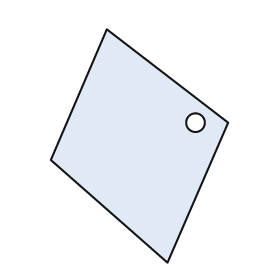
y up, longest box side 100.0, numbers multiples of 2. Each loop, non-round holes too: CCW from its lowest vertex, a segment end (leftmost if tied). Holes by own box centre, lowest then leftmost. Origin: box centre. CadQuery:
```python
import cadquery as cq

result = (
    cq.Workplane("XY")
    .moveTo(12.0, -50.0)
    .lineTo(38.0, 10.0)
    .lineTo(-14.0, 50.0)
    .lineTo(-38.0, -6.0)
    .close()
    .moveTo(24.0, 10.0)
    .circle(4.0)
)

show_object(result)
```